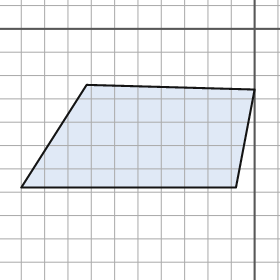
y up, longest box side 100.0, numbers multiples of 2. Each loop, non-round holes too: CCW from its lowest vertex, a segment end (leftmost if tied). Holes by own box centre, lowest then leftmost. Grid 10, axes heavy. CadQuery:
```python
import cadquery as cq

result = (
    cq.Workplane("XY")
    .moveTo(-100.0, -68.0)
    .lineTo(-8.0, -68.0)
    .lineTo(0.0, -26.0)
    .lineTo(-72.0, -24.0)
    .close()
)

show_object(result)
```